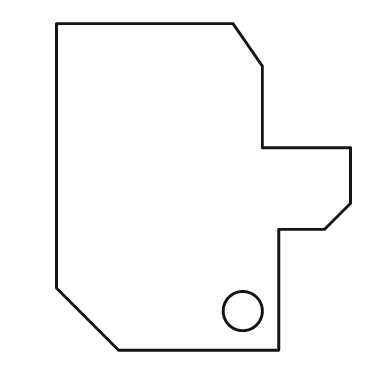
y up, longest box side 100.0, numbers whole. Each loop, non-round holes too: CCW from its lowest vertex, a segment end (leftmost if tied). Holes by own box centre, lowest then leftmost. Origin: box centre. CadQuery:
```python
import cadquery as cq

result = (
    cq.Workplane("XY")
    .moveTo(-26.0, -50.0)
    .lineTo(23.0, -50.0)
    .lineTo(23.0, -13.0)
    .lineTo(37.0, -13.0)
    .lineTo(45.0, -5.0)
    .lineTo(45.0, 12.0)
    .lineTo(18.0, 12.0)
    .lineTo(18.0, 37.0)
    .lineTo(9.0, 50.0)
    .lineTo(-45.0, 50.0)
    .lineTo(-45.0, -31.0)
    .close()
    .moveTo(12.0, -38.0)
    .circle(6.0)
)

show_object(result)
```